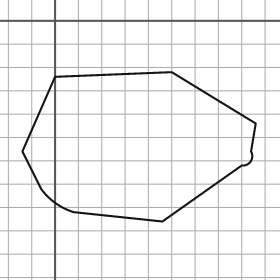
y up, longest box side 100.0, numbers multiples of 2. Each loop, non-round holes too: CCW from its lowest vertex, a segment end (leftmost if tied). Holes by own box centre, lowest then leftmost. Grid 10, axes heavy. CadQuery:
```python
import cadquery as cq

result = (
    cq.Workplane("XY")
    .moveTo(46.0, -86.0)
    .lineTo(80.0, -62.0)
    .threePointArc((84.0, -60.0), (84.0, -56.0))
    .lineTo(86.0, -44.0)
    .lineTo(50.0, -22.0)
    .lineTo(0.0, -24.0)
    .lineTo(-14.0, -56.0)
    .lineTo(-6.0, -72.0)
    .threePointArc((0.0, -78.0), (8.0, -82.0))
    .close()
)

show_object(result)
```